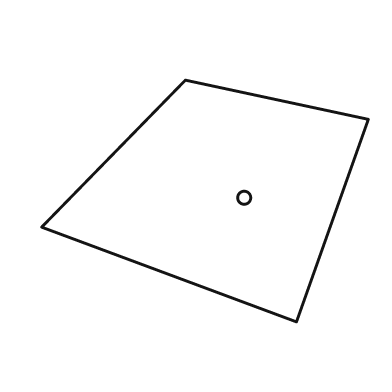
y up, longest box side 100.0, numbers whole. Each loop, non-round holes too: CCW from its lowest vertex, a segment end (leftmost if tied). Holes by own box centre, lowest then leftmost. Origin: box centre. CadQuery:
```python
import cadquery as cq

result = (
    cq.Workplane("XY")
    .moveTo(28.0, -37.0)
    .lineTo(50.0, 25.0)
    .lineTo(-6.0, 37.0)
    .lineTo(-50.0, -8.0)
    .close()
    .moveTo(12.0, 1.0)
    .circle(2.0)
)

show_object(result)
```